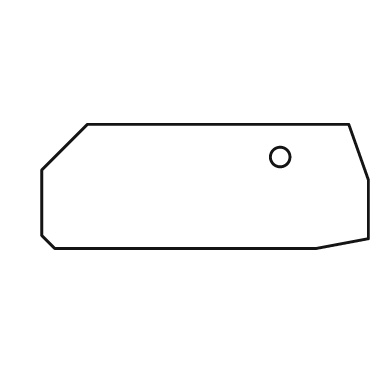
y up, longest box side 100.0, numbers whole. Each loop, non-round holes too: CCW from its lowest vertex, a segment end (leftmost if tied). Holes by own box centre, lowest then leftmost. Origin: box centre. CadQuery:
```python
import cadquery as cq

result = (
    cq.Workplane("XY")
    .moveTo(-46.0, -19.0)
    .lineTo(34.0, -19.0)
    .lineTo(50.0, -16.0)
    .lineTo(50.0, 2.0)
    .lineTo(44.0, 19.0)
    .lineTo(-36.0, 19.0)
    .lineTo(-50.0, 5.0)
    .lineTo(-50.0, -15.0)
    .close()
    .moveTo(23.0, 9.0)
    .circle(3.0)
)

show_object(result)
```